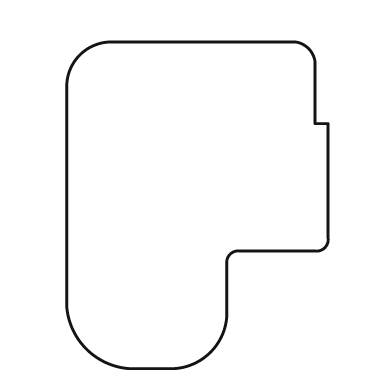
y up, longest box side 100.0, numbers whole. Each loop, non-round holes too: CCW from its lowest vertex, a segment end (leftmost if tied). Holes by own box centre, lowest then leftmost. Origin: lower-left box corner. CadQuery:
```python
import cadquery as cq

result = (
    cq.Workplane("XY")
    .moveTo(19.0, 0.0)
    .lineTo(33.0, 0.0)
    .threePointArc((44.0, 5.0), (49.0, 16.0))
    .lineTo(49.0, 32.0)
    .threePointArc((50.0, 35.0), (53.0, 36.0))
    .lineTo(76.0, 36.0)
    .threePointArc((79.0, 37.0), (80.0, 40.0))
    .lineTo(80.0, 75.0)
    .lineTo(76.0, 75.0)
    .lineTo(76.0, 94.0)
    .threePointArc((74.0, 98.0), (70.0, 100.0))
    .lineTo(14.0, 100.0)
    .threePointArc((4.0, 96.0), (0.0, 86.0))
    .lineTo(0.0, 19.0)
    .threePointArc((6.0, 6.0), (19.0, 0.0))
    .close()
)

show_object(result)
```